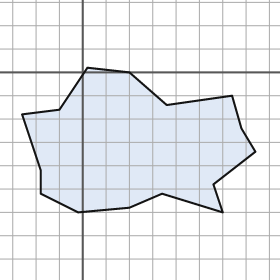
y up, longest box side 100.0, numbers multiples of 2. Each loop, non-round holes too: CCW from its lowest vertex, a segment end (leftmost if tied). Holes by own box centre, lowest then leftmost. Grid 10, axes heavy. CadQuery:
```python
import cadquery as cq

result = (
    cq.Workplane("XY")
    .moveTo(-2.0, -60.0)
    .lineTo(20.0, -58.0)
    .lineTo(34.0, -52.0)
    .lineTo(60.0, -60.0)
    .lineTo(56.0, -48.0)
    .lineTo(74.0, -34.0)
    .lineTo(68.0, -24.0)
    .lineTo(64.0, -10.0)
    .lineTo(36.0, -14.0)
    .lineTo(20.0, 0.0)
    .lineTo(2.0, 2.0)
    .lineTo(-10.0, -16.0)
    .lineTo(-26.0, -18.0)
    .lineTo(-18.0, -42.0)
    .lineTo(-18.0, -52.0)
    .close()
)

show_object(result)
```